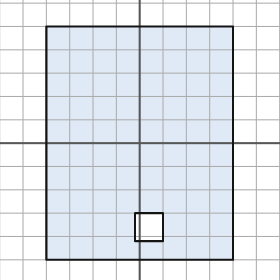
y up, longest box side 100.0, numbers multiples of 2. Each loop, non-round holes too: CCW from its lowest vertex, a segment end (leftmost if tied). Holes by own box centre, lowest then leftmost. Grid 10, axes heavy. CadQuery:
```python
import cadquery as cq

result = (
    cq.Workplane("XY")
    .moveTo(-40.0, -50.0)
    .lineTo(40.0, -50.0)
    .lineTo(40.0, 50.0)
    .lineTo(-40.0, 50.0)
    .close()
    .moveTo(-2.0, -42.0)
    .lineTo(10.0, -42.0)
    .lineTo(10.0, -30.0)
    .lineTo(-2.0, -30.0)
    .close()
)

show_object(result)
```